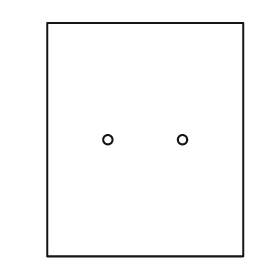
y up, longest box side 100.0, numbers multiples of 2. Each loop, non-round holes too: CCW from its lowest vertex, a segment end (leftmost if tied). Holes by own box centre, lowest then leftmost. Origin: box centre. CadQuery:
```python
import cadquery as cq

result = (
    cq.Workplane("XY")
    .moveTo(-42.0, -50.0)
    .lineTo(42.0, -50.0)
    .lineTo(42.0, 50.0)
    .lineTo(-42.0, 50.0)
    .close()
    .moveTo(-16.0, 0.0)
    .circle(2.0)
    .moveTo(16.0, 0.0)
    .circle(2.0)
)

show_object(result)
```